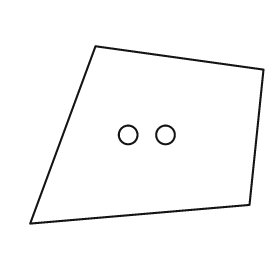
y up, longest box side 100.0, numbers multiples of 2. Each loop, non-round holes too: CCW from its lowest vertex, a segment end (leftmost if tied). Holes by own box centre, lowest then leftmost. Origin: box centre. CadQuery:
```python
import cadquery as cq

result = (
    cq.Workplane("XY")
    .moveTo(-50.0, -38.0)
    .lineTo(44.0, -30.0)
    .lineTo(50.0, 28.0)
    .lineTo(-22.0, 38.0)
    .close()
    .moveTo(-8.0, 0.0)
    .circle(4.0)
    .moveTo(8.0, 0.0)
    .circle(4.0)
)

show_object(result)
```